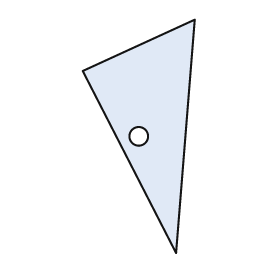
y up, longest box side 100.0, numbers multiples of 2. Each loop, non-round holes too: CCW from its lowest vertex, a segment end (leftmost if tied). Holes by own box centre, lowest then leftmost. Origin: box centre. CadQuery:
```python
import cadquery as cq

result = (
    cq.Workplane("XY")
    .moveTo(16.0, -50.0)
    .lineTo(24.0, 50.0)
    .lineTo(-24.0, 28.0)
    .close()
    .moveTo(0.0, 0.0)
    .circle(4.0)
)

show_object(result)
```